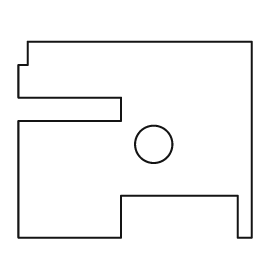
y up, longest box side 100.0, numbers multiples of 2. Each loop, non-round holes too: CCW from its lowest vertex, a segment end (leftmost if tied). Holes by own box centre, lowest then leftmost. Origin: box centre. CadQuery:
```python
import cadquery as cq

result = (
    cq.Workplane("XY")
    .moveTo(-50.0, -42.0)
    .lineTo(-6.0, -42.0)
    .lineTo(-6.0, -24.0)
    .lineTo(44.0, -24.0)
    .lineTo(44.0, -42.0)
    .lineTo(50.0, -42.0)
    .lineTo(50.0, 42.0)
    .lineTo(-46.0, 42.0)
    .lineTo(-46.0, 32.0)
    .lineTo(-50.0, 32.0)
    .lineTo(-50.0, 18.0)
    .lineTo(-6.0, 18.0)
    .lineTo(-6.0, 8.0)
    .lineTo(-50.0, 8.0)
    .close()
    .moveTo(8.0, -2.0)
    .circle(8.0)
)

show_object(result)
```